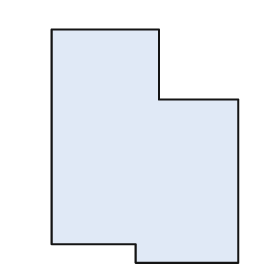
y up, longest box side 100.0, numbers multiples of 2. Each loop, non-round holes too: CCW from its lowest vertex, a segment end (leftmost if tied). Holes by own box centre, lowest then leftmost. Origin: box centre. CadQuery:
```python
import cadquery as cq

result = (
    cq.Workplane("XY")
    .moveTo(-4.0, -50.0)
    .lineTo(40.0, -50.0)
    .lineTo(40.0, 20.0)
    .lineTo(6.0, 20.0)
    .lineTo(6.0, 50.0)
    .lineTo(-40.0, 50.0)
    .lineTo(-40.0, -42.0)
    .lineTo(-4.0, -42.0)
    .close()
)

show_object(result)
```